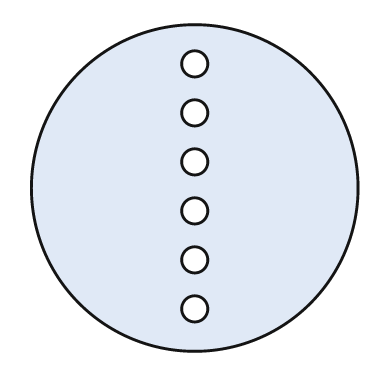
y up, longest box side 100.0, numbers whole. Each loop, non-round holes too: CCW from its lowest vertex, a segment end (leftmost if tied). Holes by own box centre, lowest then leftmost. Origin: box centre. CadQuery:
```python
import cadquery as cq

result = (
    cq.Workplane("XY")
    .moveTo(0.0, 0.0)
    .circle(50.0)
    .moveTo(0.0, -37.0)
    .circle(4.0)
    .moveTo(0.0, -22.0)
    .circle(4.0)
    .moveTo(0.0, -7.0)
    .circle(4.0)
    .moveTo(0.0, 8.0)
    .circle(4.0)
    .moveTo(0.0, 23.0)
    .circle(4.0)
    .moveTo(0.0, 38.0)
    .circle(4.0)
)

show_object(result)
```